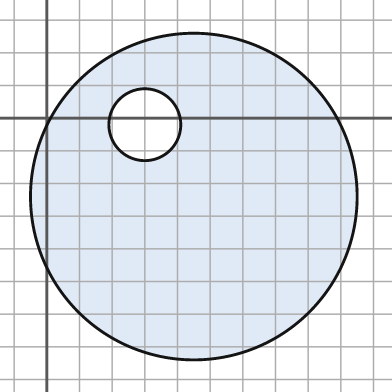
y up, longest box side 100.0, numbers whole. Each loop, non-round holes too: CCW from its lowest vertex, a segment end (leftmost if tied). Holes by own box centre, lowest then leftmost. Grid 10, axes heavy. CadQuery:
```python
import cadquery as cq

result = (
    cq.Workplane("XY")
    .moveTo(45.0, -24.0)
    .circle(50.0)
    .moveTo(30.0, -2.0)
    .circle(11.0)
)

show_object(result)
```